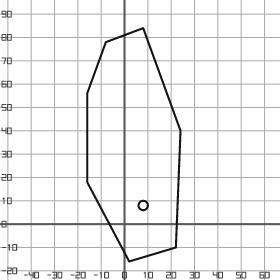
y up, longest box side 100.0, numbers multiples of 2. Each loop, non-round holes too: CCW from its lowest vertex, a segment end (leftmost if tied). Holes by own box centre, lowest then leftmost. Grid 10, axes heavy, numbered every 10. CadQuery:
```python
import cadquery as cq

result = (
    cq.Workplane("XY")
    .moveTo(2.0, -16.0)
    .lineTo(22.0, -10.0)
    .lineTo(24.0, 40.0)
    .lineTo(8.0, 84.0)
    .lineTo(-8.0, 78.0)
    .lineTo(-16.0, 56.0)
    .lineTo(-16.0, 18.0)
    .close()
    .moveTo(8.0, 8.0)
    .circle(2.0)
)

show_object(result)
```